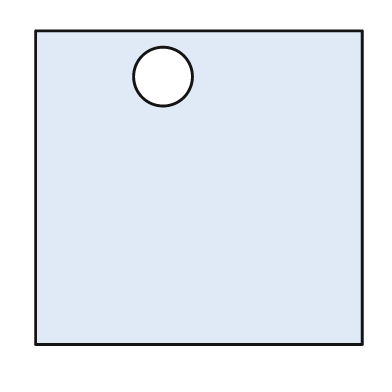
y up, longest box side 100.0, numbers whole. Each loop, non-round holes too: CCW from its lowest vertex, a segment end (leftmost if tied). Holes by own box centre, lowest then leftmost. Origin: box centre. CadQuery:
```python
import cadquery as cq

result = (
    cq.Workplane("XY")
    .moveTo(-50.0, -48.0)
    .lineTo(50.0, -48.0)
    .lineTo(50.0, 48.0)
    .lineTo(-50.0, 48.0)
    .close()
    .moveTo(-11.0, 34.0)
    .circle(9.0)
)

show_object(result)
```